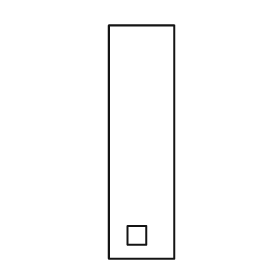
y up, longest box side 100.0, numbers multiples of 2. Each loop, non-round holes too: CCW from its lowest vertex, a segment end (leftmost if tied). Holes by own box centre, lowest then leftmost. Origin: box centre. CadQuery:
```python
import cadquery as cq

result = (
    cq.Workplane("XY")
    .moveTo(-14.0, -50.0)
    .lineTo(14.0, -50.0)
    .lineTo(14.0, 50.0)
    .lineTo(-14.0, 50.0)
    .close()
    .moveTo(-6.0, -44.0)
    .lineTo(2.0, -44.0)
    .lineTo(2.0, -36.0)
    .lineTo(-6.0, -36.0)
    .close()
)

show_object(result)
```